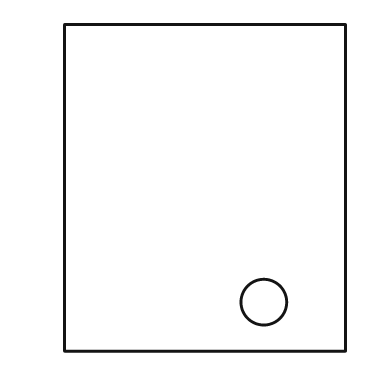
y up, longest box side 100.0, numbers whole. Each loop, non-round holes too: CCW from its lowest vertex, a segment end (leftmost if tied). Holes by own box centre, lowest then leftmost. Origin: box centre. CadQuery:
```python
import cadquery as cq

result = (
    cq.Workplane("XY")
    .moveTo(-43.0, -50.0)
    .lineTo(43.0, -50.0)
    .lineTo(43.0, 50.0)
    .lineTo(-43.0, 50.0)
    .close()
    .moveTo(18.0, -35.0)
    .circle(7.0)
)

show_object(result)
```